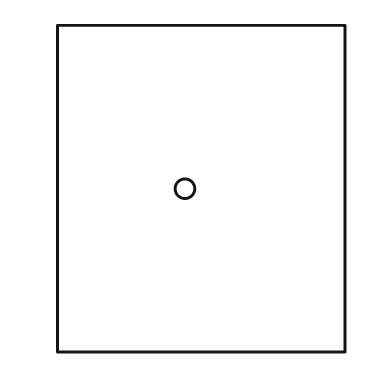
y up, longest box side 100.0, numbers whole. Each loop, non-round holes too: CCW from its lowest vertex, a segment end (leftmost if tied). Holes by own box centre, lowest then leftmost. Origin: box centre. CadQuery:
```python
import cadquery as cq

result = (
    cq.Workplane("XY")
    .moveTo(-44.0, -50.0)
    .lineTo(44.0, -50.0)
    .lineTo(44.0, 50.0)
    .lineTo(-44.0, 50.0)
    .close()
    .moveTo(-5.0, 0.0)
    .circle(3.0)
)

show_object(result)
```